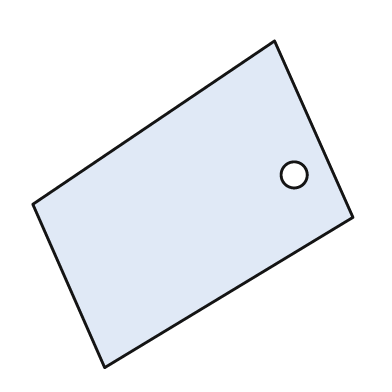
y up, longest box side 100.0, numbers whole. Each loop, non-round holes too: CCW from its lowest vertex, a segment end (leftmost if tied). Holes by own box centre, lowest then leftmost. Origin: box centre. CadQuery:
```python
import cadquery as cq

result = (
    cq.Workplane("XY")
    .moveTo(-27.0, -50.0)
    .lineTo(49.0, -4.0)
    .lineTo(25.0, 50.0)
    .lineTo(-49.0, 0.0)
    .close()
    .moveTo(31.0, 9.0)
    .circle(4.0)
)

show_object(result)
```